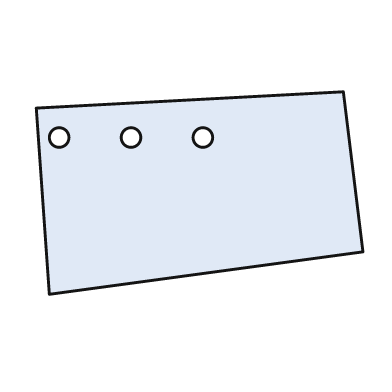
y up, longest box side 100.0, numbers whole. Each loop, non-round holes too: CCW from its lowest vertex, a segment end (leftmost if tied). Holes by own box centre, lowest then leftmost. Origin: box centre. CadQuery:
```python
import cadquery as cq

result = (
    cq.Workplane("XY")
    .moveTo(-46.0, -31.0)
    .lineTo(50.0, -18.0)
    .lineTo(44.0, 31.0)
    .lineTo(-50.0, 26.0)
    .close()
    .moveTo(-43.0, 17.0)
    .circle(3.0)
    .moveTo(-21.0, 17.0)
    .circle(3.0)
    .moveTo(1.0, 17.0)
    .circle(3.0)
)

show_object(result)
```